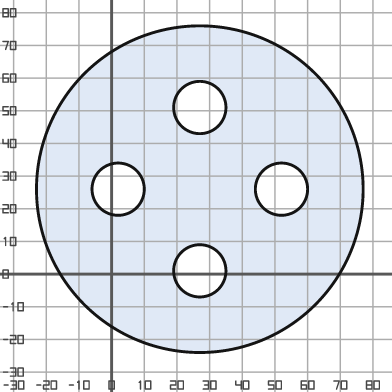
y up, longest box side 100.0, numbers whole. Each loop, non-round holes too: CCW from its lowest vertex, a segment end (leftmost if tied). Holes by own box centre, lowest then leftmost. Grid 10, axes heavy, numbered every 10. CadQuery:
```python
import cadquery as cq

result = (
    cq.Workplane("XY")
    .moveTo(27.0, 26.0)
    .circle(50.0)
    .moveTo(27.0, 1.0)
    .circle(8.0)
    .moveTo(2.0, 26.0)
    .circle(8.0)
    .moveTo(52.0, 26.0)
    .circle(8.0)
    .moveTo(27.0, 51.0)
    .circle(8.0)
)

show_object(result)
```